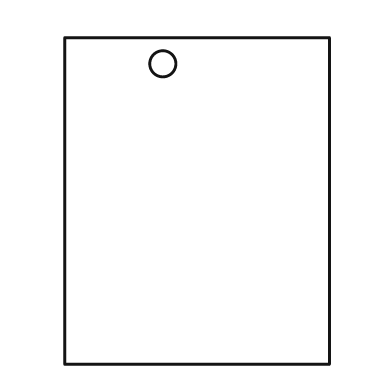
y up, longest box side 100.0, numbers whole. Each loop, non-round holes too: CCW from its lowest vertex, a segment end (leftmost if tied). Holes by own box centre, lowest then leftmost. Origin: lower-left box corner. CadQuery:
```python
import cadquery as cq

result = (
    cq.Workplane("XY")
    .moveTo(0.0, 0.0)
    .lineTo(81.0, 0.0)
    .lineTo(81.0, 100.0)
    .lineTo(0.0, 100.0)
    .close()
    .moveTo(30.0, 92.0)
    .circle(4.0)
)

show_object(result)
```